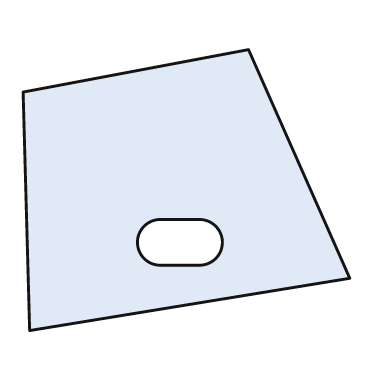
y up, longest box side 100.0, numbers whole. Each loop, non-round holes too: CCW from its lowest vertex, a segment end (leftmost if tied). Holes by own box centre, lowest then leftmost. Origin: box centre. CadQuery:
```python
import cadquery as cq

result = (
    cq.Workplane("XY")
    .moveTo(-48.0, -43.0)
    .lineTo(50.0, -27.0)
    .lineTo(19.0, 43.0)
    .lineTo(-50.0, 30.0)
    .close()
    .moveTo(-8.0, -23.0)
    .lineTo(4.0, -23.0)
    .threePointArc((11.0, -16.0), (4.0, -9.0))
    .lineTo(-8.0, -9.0)
    .threePointArc((-15.0, -16.0), (-8.0, -23.0))
    .close()
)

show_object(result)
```